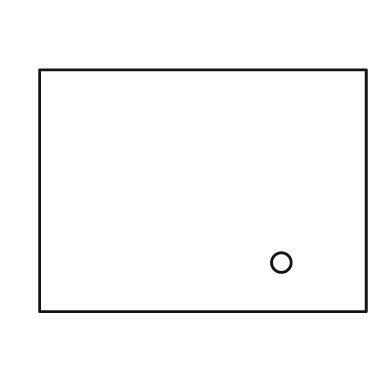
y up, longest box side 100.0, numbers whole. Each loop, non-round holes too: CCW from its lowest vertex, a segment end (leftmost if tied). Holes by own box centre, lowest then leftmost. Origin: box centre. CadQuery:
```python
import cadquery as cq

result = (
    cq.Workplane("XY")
    .moveTo(-50.0, -37.0)
    .lineTo(50.0, -37.0)
    .lineTo(50.0, 37.0)
    .lineTo(-50.0, 37.0)
    .close()
    .moveTo(24.0, -22.0)
    .circle(3.0)
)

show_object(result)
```